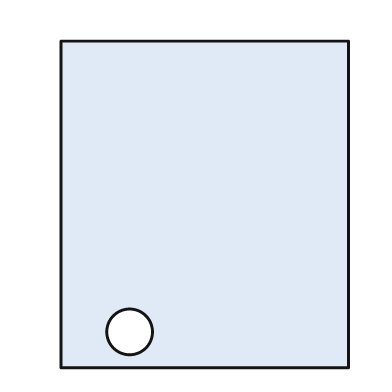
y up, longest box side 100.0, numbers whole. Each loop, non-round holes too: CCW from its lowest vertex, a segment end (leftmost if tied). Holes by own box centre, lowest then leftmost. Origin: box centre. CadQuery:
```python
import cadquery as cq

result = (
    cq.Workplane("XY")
    .moveTo(-44.0, -50.0)
    .lineTo(44.0, -50.0)
    .lineTo(44.0, 50.0)
    .lineTo(-44.0, 50.0)
    .close()
    .moveTo(-23.0, -39.0)
    .circle(7.0)
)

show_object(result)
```